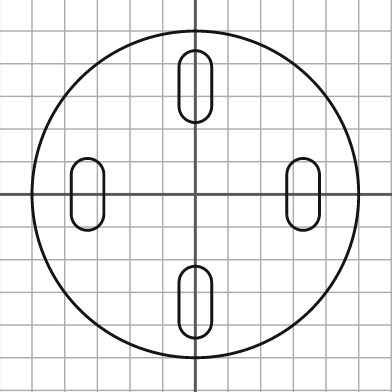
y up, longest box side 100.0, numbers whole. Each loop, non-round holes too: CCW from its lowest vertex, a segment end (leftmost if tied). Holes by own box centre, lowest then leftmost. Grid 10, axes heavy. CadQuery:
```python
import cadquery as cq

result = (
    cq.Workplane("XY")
    .moveTo(0.0, 0.0)
    .circle(50.0)
    .moveTo(-5.0, -39.0)
    .threePointArc((0.0, -44.0), (5.0, -39.0))
    .lineTo(5.0, -27.0)
    .threePointArc((0.0, -22.0), (-5.0, -27.0))
    .close()
    .moveTo(-38.0, -6.0)
    .threePointArc((-33.0, -11.0), (-28.0, -6.0))
    .lineTo(-28.0, 6.0)
    .threePointArc((-33.0, 11.0), (-38.0, 6.0))
    .close()
    .moveTo(28.0, -6.0)
    .threePointArc((33.0, -11.0), (38.0, -6.0))
    .lineTo(38.0, 6.0)
    .threePointArc((33.0, 11.0), (28.0, 6.0))
    .close()
    .moveTo(-5.0, 27.0)
    .threePointArc((0.0, 22.0), (5.0, 27.0))
    .lineTo(5.0, 39.0)
    .threePointArc((0.0, 44.0), (-5.0, 39.0))
    .close()
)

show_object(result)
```